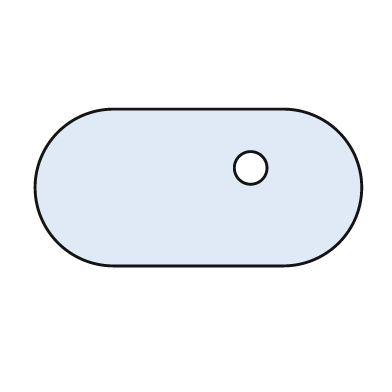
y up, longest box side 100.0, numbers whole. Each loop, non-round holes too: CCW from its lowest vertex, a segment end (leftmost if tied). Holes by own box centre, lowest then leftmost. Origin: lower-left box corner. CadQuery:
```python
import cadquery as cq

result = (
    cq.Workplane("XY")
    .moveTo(24.0, 0.0)
    .lineTo(76.0, 0.0)
    .threePointArc((100.0, 24.0), (76.0, 48.0))
    .lineTo(24.0, 48.0)
    .threePointArc((0.0, 24.0), (24.0, 0.0))
    .close()
    .moveTo(66.0, 30.0)
    .circle(5.0)
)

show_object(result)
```